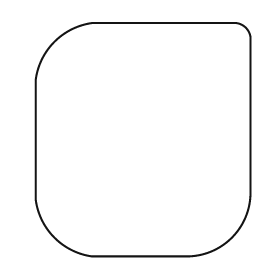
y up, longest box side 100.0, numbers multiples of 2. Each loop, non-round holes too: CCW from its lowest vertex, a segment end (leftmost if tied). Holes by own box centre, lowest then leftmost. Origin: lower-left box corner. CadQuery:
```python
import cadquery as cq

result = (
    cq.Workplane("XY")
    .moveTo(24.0, 0.0)
    .lineTo(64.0, 0.0)
    .threePointArc((84.0, 8.0), (92.0, 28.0))
    .lineTo(92.0, 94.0)
    .threePointArc((90.0, 98.0), (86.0, 100.0))
    .lineTo(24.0, 100.0)
    .threePointArc((8.0, 92.0), (0.0, 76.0))
    .lineTo(0.0, 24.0)
    .threePointArc((8.0, 8.0), (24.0, 0.0))
    .close()
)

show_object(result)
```